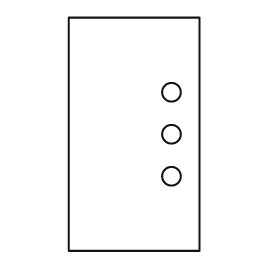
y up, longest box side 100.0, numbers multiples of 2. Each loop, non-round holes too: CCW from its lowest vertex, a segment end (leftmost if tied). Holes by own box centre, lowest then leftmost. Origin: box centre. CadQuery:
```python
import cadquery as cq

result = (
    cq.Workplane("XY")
    .moveTo(-28.0, -50.0)
    .lineTo(28.0, -50.0)
    .lineTo(28.0, 50.0)
    .lineTo(-28.0, 50.0)
    .close()
    .moveTo(16.0, -18.0)
    .circle(4.0)
    .moveTo(16.0, 0.0)
    .circle(4.0)
    .moveTo(16.0, 18.0)
    .circle(4.0)
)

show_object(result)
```